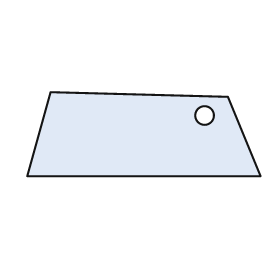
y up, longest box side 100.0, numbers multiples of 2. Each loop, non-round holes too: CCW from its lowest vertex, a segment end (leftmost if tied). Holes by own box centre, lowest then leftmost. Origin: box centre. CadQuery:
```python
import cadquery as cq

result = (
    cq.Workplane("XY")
    .moveTo(-50.0, -18.0)
    .lineTo(50.0, -18.0)
    .lineTo(36.0, 16.0)
    .lineTo(-40.0, 18.0)
    .close()
    .moveTo(26.0, 8.0)
    .circle(4.0)
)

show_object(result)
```